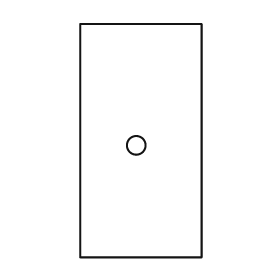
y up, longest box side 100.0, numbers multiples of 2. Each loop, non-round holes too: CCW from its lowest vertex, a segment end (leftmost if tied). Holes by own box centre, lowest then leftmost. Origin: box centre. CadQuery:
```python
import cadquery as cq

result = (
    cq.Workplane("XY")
    .moveTo(-26.0, -50.0)
    .lineTo(26.0, -50.0)
    .lineTo(26.0, 50.0)
    .lineTo(-26.0, 50.0)
    .close()
    .moveTo(-2.0, -2.0)
    .circle(4.0)
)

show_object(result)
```